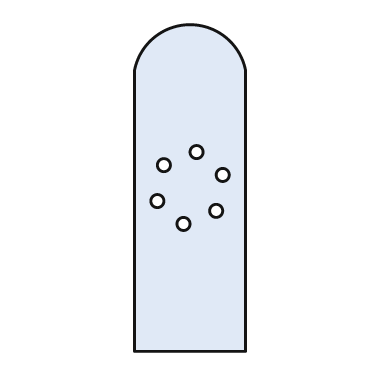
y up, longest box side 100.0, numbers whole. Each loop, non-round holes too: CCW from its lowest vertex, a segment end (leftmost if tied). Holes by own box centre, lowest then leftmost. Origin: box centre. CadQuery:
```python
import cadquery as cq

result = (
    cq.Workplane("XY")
    .moveTo(-17.0, -50.0)
    .lineTo(17.0, -50.0)
    .lineTo(17.0, 36.0)
    .threePointArc((0.0, 50.0), (-17.0, 36.0))
    .close()
    .moveTo(-2.0, -11.0)
    .circle(2.0)
    .moveTo(8.0, -7.0)
    .circle(2.0)
    .moveTo(-10.0, -4.0)
    .circle(2.0)
    .moveTo(10.0, 4.0)
    .circle(2.0)
    .moveTo(-8.0, 7.0)
    .circle(2.0)
    .moveTo(2.0, 11.0)
    .circle(2.0)
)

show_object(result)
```